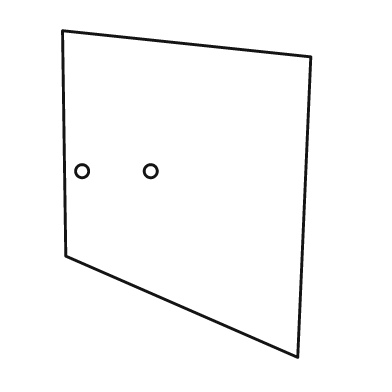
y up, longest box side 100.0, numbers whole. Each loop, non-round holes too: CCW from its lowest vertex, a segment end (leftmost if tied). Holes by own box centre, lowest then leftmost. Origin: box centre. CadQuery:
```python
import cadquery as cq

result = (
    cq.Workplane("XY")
    .moveTo(34.0, -50.0)
    .lineTo(38.0, 42.0)
    .lineTo(-38.0, 50.0)
    .lineTo(-37.0, -19.0)
    .close()
    .moveTo(-32.0, 7.0)
    .circle(2.0)
    .moveTo(-11.0, 7.0)
    .circle(2.0)
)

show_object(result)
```